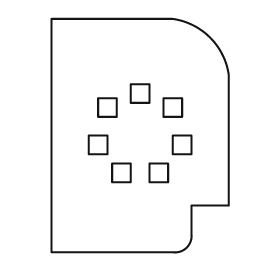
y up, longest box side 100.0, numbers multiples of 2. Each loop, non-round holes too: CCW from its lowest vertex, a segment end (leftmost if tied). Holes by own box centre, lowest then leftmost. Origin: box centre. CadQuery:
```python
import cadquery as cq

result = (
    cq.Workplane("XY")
    .moveTo(-38.0, -50.0)
    .lineTo(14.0, -50.0)
    .threePointArc((20.0, -48.0), (22.0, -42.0))
    .lineTo(22.0, -30.0)
    .lineTo(38.0, -30.0)
    .lineTo(38.0, 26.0)
    .threePointArc((30.0, 42.0), (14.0, 50.0))
    .lineTo(-38.0, 50.0)
    .close()
    .moveTo(-12.0, -20.0)
    .lineTo(-4.0, -20.0)
    .lineTo(-4.0, -12.0)
    .lineTo(-12.0, -12.0)
    .close()
    .moveTo(4.0, -20.0)
    .lineTo(12.0, -20.0)
    .lineTo(12.0, -12.0)
    .lineTo(4.0, -12.0)
    .close()
    .moveTo(-22.0, -8.0)
    .lineTo(-14.0, -8.0)
    .lineTo(-14.0, 0.0)
    .lineTo(-22.0, 0.0)
    .close()
    .moveTo(14.0, -8.0)
    .lineTo(22.0, -8.0)
    .lineTo(22.0, 0.0)
    .lineTo(14.0, 0.0)
    .close()
    .moveTo(-18.0, 8.0)
    .lineTo(-10.0, 8.0)
    .lineTo(-10.0, 16.0)
    .lineTo(-18.0, 16.0)
    .close()
    .moveTo(10.0, 8.0)
    .lineTo(18.0, 8.0)
    .lineTo(18.0, 16.0)
    .lineTo(10.0, 16.0)
    .close()
    .moveTo(-4.0, 14.0)
    .lineTo(4.0, 14.0)
    .lineTo(4.0, 22.0)
    .lineTo(-4.0, 22.0)
    .close()
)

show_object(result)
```